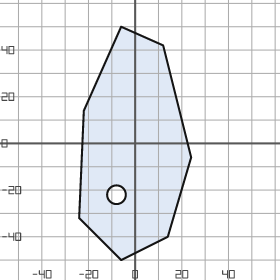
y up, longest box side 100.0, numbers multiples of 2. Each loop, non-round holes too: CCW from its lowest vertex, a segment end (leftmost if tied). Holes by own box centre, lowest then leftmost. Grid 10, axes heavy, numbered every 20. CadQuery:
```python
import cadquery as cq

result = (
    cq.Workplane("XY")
    .moveTo(-6.0, -50.0)
    .lineTo(14.0, -40.0)
    .lineTo(24.0, -6.0)
    .lineTo(12.0, 42.0)
    .lineTo(-6.0, 50.0)
    .lineTo(-22.0, 14.0)
    .lineTo(-24.0, -32.0)
    .close()
    .moveTo(-8.0, -22.0)
    .circle(4.0)
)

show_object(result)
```